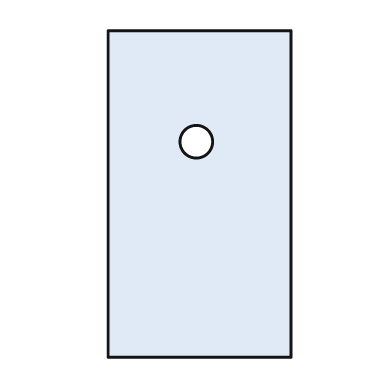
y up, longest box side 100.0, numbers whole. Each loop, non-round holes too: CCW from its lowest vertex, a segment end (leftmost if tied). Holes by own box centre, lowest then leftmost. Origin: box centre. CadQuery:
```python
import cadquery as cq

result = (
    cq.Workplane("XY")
    .moveTo(-28.0, -50.0)
    .lineTo(28.0, -50.0)
    .lineTo(28.0, 50.0)
    .lineTo(-28.0, 50.0)
    .close()
    .moveTo(-1.0, 16.0)
    .circle(5.0)
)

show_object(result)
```